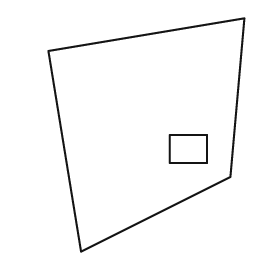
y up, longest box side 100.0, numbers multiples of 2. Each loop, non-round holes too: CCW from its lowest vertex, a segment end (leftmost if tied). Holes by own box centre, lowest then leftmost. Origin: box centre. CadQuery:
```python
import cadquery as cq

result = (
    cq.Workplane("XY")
    .moveTo(-28.0, -50.0)
    .lineTo(36.0, -18.0)
    .lineTo(42.0, 50.0)
    .lineTo(-42.0, 36.0)
    .close()
    .moveTo(10.0, -12.0)
    .lineTo(26.0, -12.0)
    .lineTo(26.0, 0.0)
    .lineTo(10.0, 0.0)
    .close()
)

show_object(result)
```